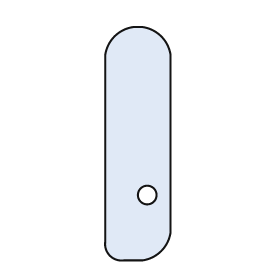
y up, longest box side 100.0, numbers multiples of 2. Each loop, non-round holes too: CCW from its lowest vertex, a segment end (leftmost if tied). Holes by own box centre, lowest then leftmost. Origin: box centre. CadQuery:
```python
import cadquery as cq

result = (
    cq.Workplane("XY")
    .moveTo(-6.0, -50.0)
    .lineTo(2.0, -50.0)
    .threePointArc((10.0, -46.0), (14.0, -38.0))
    .lineTo(14.0, 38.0)
    .threePointArc((10.0, 46.0), (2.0, 50.0))
    .lineTo(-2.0, 50.0)
    .threePointArc((-10.0, 46.0), (-14.0, 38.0))
    .lineTo(-14.0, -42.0)
    .threePointArc((-12.0, -48.0), (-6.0, -50.0))
    .close()
    .moveTo(4.0, -22.0)
    .circle(4.0)
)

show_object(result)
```